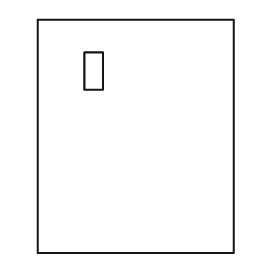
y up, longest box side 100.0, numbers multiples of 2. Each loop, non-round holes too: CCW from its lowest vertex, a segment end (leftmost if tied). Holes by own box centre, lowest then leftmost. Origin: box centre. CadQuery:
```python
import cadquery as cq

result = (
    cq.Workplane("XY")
    .moveTo(-42.0, -50.0)
    .lineTo(42.0, -50.0)
    .lineTo(42.0, 50.0)
    .lineTo(-42.0, 50.0)
    .close()
    .moveTo(-22.0, 20.0)
    .lineTo(-14.0, 20.0)
    .lineTo(-14.0, 36.0)
    .lineTo(-22.0, 36.0)
    .close()
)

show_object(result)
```